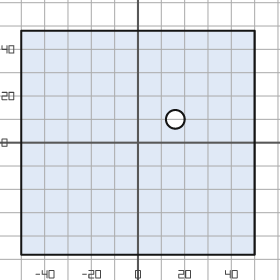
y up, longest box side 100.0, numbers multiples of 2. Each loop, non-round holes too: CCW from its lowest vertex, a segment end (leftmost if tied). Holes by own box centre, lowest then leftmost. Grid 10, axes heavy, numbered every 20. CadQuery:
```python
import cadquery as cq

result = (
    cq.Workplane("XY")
    .moveTo(-50.0, -48.0)
    .lineTo(50.0, -48.0)
    .lineTo(50.0, 48.0)
    .lineTo(-50.0, 48.0)
    .close()
    .moveTo(16.0, 10.0)
    .circle(4.0)
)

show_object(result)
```